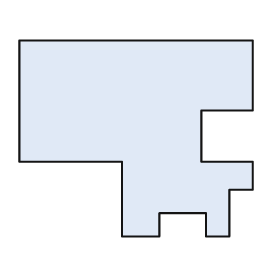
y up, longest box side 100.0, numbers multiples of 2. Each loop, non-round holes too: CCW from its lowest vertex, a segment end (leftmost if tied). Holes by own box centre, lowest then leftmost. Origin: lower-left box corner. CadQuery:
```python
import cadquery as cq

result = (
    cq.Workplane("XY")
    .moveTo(44.0, 0.0)
    .lineTo(60.0, 0.0)
    .lineTo(60.0, 10.0)
    .lineTo(80.0, 10.0)
    .lineTo(80.0, 0.0)
    .lineTo(90.0, 0.0)
    .lineTo(90.0, 20.0)
    .lineTo(100.0, 20.0)
    .lineTo(100.0, 32.0)
    .lineTo(78.0, 32.0)
    .lineTo(78.0, 54.0)
    .lineTo(100.0, 54.0)
    .lineTo(100.0, 84.0)
    .lineTo(0.0, 84.0)
    .lineTo(0.0, 32.0)
    .lineTo(44.0, 32.0)
    .close()
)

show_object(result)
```